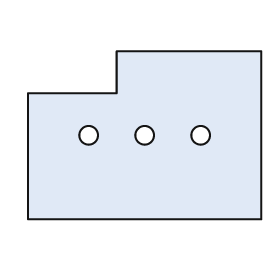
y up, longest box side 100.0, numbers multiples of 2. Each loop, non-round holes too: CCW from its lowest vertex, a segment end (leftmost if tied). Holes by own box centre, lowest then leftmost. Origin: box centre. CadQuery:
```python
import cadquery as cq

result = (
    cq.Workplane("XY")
    .moveTo(-50.0, -36.0)
    .lineTo(50.0, -36.0)
    .lineTo(50.0, 36.0)
    .lineTo(-12.0, 36.0)
    .lineTo(-12.0, 18.0)
    .lineTo(-50.0, 18.0)
    .close()
    .moveTo(-24.0, 0.0)
    .circle(4.0)
    .moveTo(0.0, 0.0)
    .circle(4.0)
    .moveTo(24.0, 0.0)
    .circle(4.0)
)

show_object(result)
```